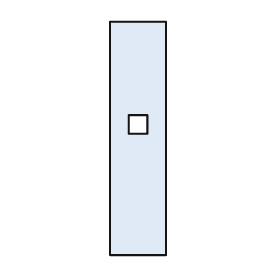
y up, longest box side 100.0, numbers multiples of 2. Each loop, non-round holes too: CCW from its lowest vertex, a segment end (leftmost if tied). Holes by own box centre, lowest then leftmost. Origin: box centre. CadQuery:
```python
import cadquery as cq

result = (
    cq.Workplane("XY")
    .moveTo(-12.0, -50.0)
    .lineTo(12.0, -50.0)
    .lineTo(12.0, 50.0)
    .lineTo(-12.0, 50.0)
    .close()
    .moveTo(-4.0, 2.0)
    .lineTo(4.0, 2.0)
    .lineTo(4.0, 10.0)
    .lineTo(-4.0, 10.0)
    .close()
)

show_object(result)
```